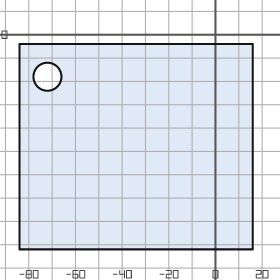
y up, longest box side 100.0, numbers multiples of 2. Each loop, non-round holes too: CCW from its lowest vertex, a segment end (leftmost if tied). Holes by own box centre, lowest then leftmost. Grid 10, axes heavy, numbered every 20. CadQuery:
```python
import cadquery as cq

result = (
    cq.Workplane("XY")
    .moveTo(-84.0, -92.0)
    .lineTo(16.0, -92.0)
    .lineTo(16.0, -4.0)
    .lineTo(-84.0, -4.0)
    .close()
    .moveTo(-72.0, -18.0)
    .circle(6.0)
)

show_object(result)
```